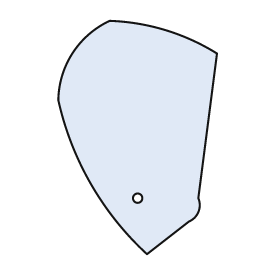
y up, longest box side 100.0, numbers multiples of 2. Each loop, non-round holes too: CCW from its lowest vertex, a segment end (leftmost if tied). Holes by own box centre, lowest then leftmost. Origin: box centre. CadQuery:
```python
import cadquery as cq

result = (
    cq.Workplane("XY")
    .moveTo(4.0, -50.0)
    .lineTo(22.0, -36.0)
    .threePointArc((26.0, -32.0), (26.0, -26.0))
    .lineTo(34.0, 36.0)
    .threePointArc((12.0, 46.0), (-12.0, 50.0))
    .threePointArc((-28.0, 36.0), (-34.0, 16.0))
    .threePointArc((-20.0, -20.0), (4.0, -50.0))
    .close()
    .moveTo(0.0, -26.0)
    .circle(2.0)
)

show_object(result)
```